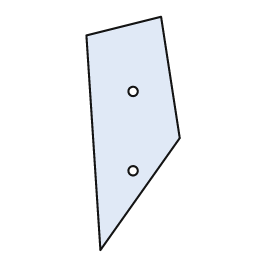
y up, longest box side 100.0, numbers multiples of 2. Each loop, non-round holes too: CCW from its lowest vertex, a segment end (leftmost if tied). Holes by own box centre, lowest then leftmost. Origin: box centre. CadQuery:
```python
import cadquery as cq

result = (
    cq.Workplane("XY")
    .moveTo(-14.0, -50.0)
    .lineTo(20.0, -2.0)
    .lineTo(12.0, 50.0)
    .lineTo(-20.0, 42.0)
    .close()
    .moveTo(0.0, -16.0)
    .circle(2.0)
    .moveTo(0.0, 18.0)
    .circle(2.0)
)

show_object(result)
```